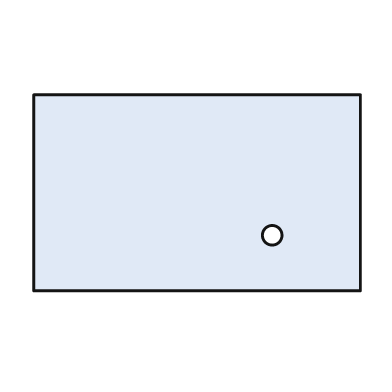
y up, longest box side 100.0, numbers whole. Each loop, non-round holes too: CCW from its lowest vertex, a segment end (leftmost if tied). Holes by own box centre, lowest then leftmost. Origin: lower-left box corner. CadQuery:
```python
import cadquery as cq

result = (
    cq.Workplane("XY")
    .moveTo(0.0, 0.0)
    .lineTo(100.0, 0.0)
    .lineTo(100.0, 60.0)
    .lineTo(0.0, 60.0)
    .close()
    .moveTo(73.0, 17.0)
    .circle(3.0)
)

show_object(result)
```